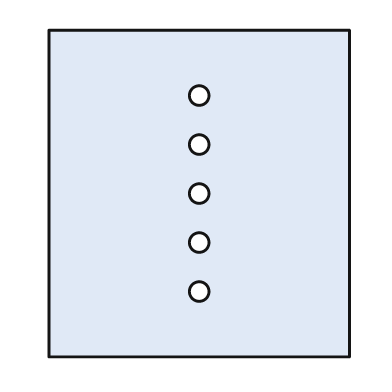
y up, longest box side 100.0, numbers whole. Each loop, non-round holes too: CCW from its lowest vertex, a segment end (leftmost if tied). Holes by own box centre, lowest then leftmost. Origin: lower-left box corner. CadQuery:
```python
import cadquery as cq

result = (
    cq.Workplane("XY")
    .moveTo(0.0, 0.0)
    .lineTo(92.0, 0.0)
    .lineTo(92.0, 100.0)
    .lineTo(0.0, 100.0)
    .close()
    .moveTo(46.0, 20.0)
    .circle(3.0)
    .moveTo(46.0, 35.0)
    .circle(3.0)
    .moveTo(46.0, 50.0)
    .circle(3.0)
    .moveTo(46.0, 65.0)
    .circle(3.0)
    .moveTo(46.0, 80.0)
    .circle(3.0)
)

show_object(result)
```